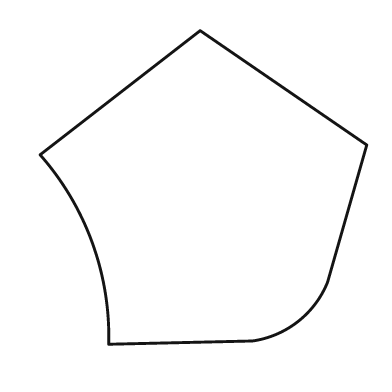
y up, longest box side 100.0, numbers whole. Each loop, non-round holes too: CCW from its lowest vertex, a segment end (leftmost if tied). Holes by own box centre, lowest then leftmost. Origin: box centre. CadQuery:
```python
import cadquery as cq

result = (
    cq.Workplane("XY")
    .moveTo(-29.0, -48.0)
    .lineTo(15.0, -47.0)
    .threePointArc((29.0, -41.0), (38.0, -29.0))
    .lineTo(50.0, 13.0)
    .lineTo(-1.0, 48.0)
    .lineTo(-50.0, 10.0)
    .threePointArc((-34.0, -17.0), (-29.0, -48.0))
    .close()
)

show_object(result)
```